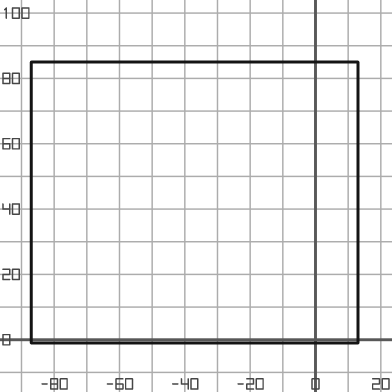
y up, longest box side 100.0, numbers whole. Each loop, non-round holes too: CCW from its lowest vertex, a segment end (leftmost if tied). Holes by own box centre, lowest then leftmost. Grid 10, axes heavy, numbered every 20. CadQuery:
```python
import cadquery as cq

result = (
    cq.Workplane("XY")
    .moveTo(-87.0, -1.0)
    .lineTo(13.0, -1.0)
    .lineTo(13.0, 85.0)
    .lineTo(-87.0, 85.0)
    .close()
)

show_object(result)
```